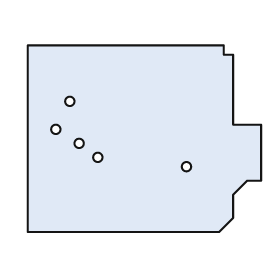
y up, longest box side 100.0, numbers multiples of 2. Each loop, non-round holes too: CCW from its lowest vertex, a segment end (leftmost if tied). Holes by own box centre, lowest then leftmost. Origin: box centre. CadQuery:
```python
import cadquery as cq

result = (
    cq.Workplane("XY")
    .moveTo(-50.0, -40.0)
    .lineTo(32.0, -40.0)
    .lineTo(38.0, -34.0)
    .lineTo(38.0, -24.0)
    .lineTo(44.0, -18.0)
    .lineTo(50.0, -18.0)
    .lineTo(50.0, 6.0)
    .lineTo(38.0, 6.0)
    .lineTo(38.0, 36.0)
    .lineTo(34.0, 36.0)
    .lineTo(34.0, 40.0)
    .lineTo(-50.0, 40.0)
    .close()
    .moveTo(18.0, -12.0)
    .circle(2.0)
    .moveTo(-20.0, -8.0)
    .circle(2.0)
    .moveTo(-28.0, -2.0)
    .circle(2.0)
    .moveTo(-38.0, 4.0)
    .circle(2.0)
    .moveTo(-32.0, 16.0)
    .circle(2.0)
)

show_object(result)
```